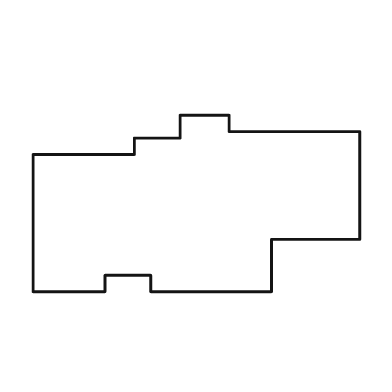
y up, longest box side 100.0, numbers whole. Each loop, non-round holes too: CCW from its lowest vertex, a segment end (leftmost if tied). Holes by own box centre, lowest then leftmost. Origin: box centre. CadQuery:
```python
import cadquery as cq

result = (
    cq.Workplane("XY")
    .moveTo(-50.0, -27.0)
    .lineTo(-28.0, -27.0)
    .lineTo(-28.0, -22.0)
    .lineTo(-14.0, -22.0)
    .lineTo(-14.0, -27.0)
    .lineTo(23.0, -27.0)
    .lineTo(23.0, -11.0)
    .lineTo(50.0, -11.0)
    .lineTo(50.0, 22.0)
    .lineTo(10.0, 22.0)
    .lineTo(10.0, 27.0)
    .lineTo(-5.0, 27.0)
    .lineTo(-5.0, 20.0)
    .lineTo(-19.0, 20.0)
    .lineTo(-19.0, 15.0)
    .lineTo(-50.0, 15.0)
    .close()
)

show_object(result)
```